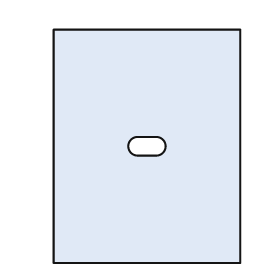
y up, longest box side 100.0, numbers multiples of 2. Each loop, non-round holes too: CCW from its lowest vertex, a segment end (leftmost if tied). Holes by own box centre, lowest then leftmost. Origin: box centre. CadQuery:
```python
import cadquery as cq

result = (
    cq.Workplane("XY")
    .moveTo(-40.0, -50.0)
    .lineTo(40.0, -50.0)
    .lineTo(40.0, 50.0)
    .lineTo(-40.0, 50.0)
    .close()
    .moveTo(-4.0, -4.0)
    .lineTo(4.0, -4.0)
    .threePointArc((8.0, 0.0), (4.0, 4.0))
    .lineTo(-4.0, 4.0)
    .threePointArc((-8.0, 0.0), (-4.0, -4.0))
    .close()
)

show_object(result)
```